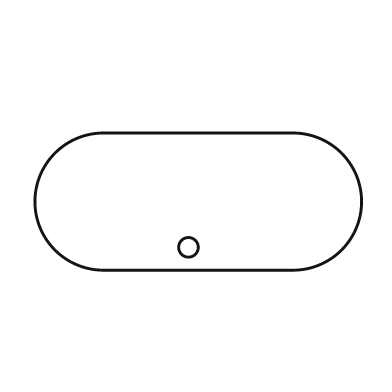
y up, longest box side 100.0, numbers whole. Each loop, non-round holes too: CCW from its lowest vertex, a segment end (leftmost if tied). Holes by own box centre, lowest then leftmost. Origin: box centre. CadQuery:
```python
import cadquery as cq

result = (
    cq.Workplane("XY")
    .moveTo(-29.0, -21.0)
    .lineTo(29.0, -21.0)
    .threePointArc((50.0, 0.0), (29.0, 21.0))
    .lineTo(-29.0, 21.0)
    .threePointArc((-50.0, 0.0), (-29.0, -21.0))
    .close()
    .moveTo(-3.0, -14.0)
    .circle(3.0)
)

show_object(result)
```